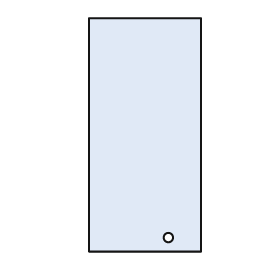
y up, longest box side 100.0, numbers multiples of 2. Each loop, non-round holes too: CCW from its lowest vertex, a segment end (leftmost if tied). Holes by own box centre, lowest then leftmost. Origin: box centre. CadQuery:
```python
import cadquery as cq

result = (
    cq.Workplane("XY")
    .moveTo(-24.0, -50.0)
    .lineTo(24.0, -50.0)
    .lineTo(24.0, 50.0)
    .lineTo(-24.0, 50.0)
    .close()
    .moveTo(10.0, -44.0)
    .circle(2.0)
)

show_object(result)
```